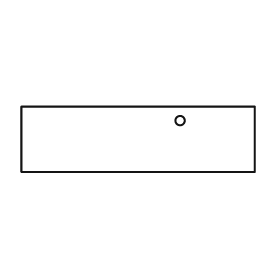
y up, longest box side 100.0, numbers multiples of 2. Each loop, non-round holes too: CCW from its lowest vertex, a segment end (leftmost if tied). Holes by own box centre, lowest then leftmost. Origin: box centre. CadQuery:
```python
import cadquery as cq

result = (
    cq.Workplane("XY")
    .moveTo(-50.0, -14.0)
    .lineTo(50.0, -14.0)
    .lineTo(50.0, 14.0)
    .lineTo(-50.0, 14.0)
    .close()
    .moveTo(18.0, 8.0)
    .circle(2.0)
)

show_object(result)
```